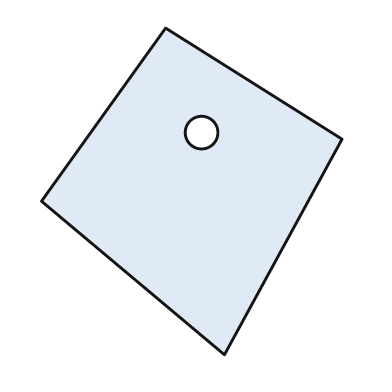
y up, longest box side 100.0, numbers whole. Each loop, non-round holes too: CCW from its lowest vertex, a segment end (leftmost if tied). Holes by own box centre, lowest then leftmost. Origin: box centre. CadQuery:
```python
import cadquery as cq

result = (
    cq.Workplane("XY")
    .moveTo(10.0, -50.0)
    .lineTo(46.0, 16.0)
    .lineTo(-8.0, 50.0)
    .lineTo(-46.0, -3.0)
    .close()
    .moveTo(3.0, 18.0)
    .circle(5.0)
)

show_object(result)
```